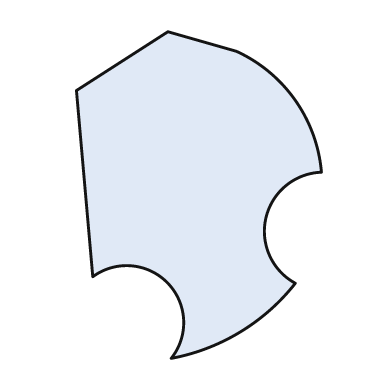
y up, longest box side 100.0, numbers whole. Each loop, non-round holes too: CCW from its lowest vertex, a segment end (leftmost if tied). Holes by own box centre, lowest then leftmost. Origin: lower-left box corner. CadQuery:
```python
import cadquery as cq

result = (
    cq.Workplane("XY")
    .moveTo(29.0, 0.0)
    .threePointArc((50.0, 8.0), (67.0, 23.0))
    .threePointArc((58.0, 43.0), (75.0, 57.0))
    .threePointArc((67.0, 79.0), (49.0, 94.0))
    .lineTo(28.0, 100.0)
    .lineTo(0.0, 82.0)
    .lineTo(5.0, 25.0)
    .threePointArc((28.0, 23.0), (29.0, 0.0))
    .close()
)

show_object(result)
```